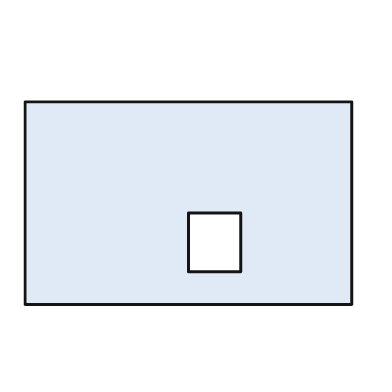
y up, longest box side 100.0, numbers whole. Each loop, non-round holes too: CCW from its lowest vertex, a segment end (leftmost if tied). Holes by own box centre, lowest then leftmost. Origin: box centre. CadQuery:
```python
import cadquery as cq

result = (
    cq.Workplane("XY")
    .moveTo(-50.0, -31.0)
    .lineTo(50.0, -31.0)
    .lineTo(50.0, 31.0)
    .lineTo(-50.0, 31.0)
    .close()
    .moveTo(0.0, -21.0)
    .lineTo(16.0, -21.0)
    .lineTo(16.0, -3.0)
    .lineTo(0.0, -3.0)
    .close()
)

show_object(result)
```